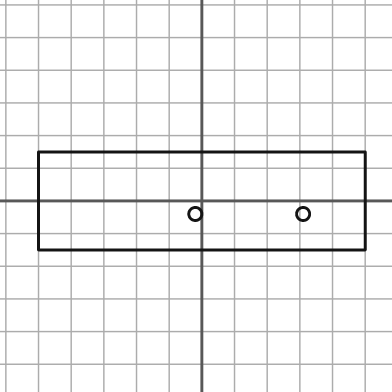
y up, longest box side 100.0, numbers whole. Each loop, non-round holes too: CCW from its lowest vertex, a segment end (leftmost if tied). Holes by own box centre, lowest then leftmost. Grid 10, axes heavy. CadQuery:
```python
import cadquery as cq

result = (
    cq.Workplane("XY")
    .moveTo(-50.0, -15.0)
    .lineTo(50.0, -15.0)
    .lineTo(50.0, 15.0)
    .lineTo(-50.0, 15.0)
    .close()
    .moveTo(-2.0, -4.0)
    .circle(2.0)
    .moveTo(31.0, -4.0)
    .circle(2.0)
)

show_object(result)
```